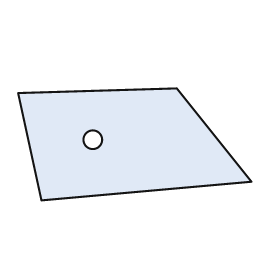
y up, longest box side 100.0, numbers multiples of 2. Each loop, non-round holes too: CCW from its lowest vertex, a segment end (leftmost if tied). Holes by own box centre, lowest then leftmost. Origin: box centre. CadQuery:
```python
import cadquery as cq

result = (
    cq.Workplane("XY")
    .moveTo(-40.0, -24.0)
    .lineTo(50.0, -16.0)
    .lineTo(18.0, 24.0)
    .lineTo(-50.0, 22.0)
    .close()
    .moveTo(-18.0, 2.0)
    .circle(4.0)
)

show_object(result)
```